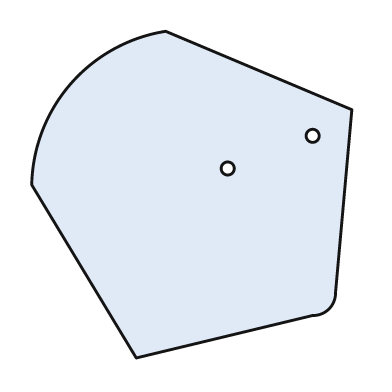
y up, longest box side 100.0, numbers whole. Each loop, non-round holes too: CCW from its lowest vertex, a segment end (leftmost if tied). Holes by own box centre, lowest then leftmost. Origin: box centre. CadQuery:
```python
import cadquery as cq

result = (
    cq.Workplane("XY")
    .moveTo(-17.0, -50.0)
    .lineTo(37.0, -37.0)
    .threePointArc((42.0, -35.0), (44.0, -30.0))
    .lineTo(49.0, 26.0)
    .lineTo(-8.0, 50.0)
    .threePointArc((-37.0, 34.0), (-49.0, 3.0))
    .close()
    .moveTo(11.0, 8.0)
    .circle(2.0)
    .moveTo(37.0, 18.0)
    .circle(2.0)
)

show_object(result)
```